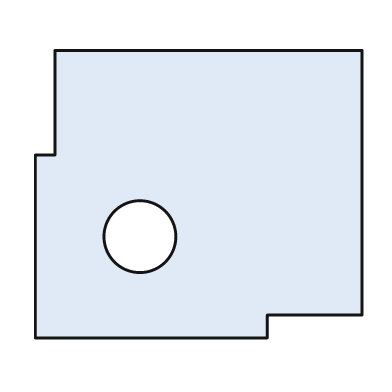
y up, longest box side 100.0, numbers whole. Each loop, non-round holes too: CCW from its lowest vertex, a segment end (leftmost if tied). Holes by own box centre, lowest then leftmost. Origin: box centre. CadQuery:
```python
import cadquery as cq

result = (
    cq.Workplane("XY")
    .moveTo(-50.0, -44.0)
    .lineTo(21.0, -44.0)
    .lineTo(21.0, -37.0)
    .lineTo(50.0, -37.0)
    .lineTo(50.0, 44.0)
    .lineTo(-44.0, 44.0)
    .lineTo(-44.0, 12.0)
    .lineTo(-50.0, 12.0)
    .close()
    .moveTo(-18.0, -13.0)
    .circle(11.0)
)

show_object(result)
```